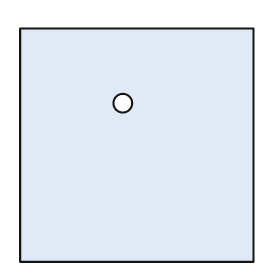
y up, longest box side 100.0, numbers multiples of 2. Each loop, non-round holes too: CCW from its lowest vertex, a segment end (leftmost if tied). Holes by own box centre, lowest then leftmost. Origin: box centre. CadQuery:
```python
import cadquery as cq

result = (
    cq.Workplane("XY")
    .moveTo(-50.0, -50.0)
    .lineTo(50.0, -50.0)
    .lineTo(50.0, 50.0)
    .lineTo(-50.0, 50.0)
    .close()
    .moveTo(-6.0, 18.0)
    .circle(4.0)
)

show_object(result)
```